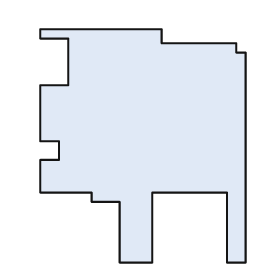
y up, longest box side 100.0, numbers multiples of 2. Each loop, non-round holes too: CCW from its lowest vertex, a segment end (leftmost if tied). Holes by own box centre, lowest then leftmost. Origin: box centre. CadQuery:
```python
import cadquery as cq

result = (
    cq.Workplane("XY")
    .moveTo(-10.0, -50.0)
    .lineTo(4.0, -50.0)
    .lineTo(4.0, -20.0)
    .lineTo(36.0, -20.0)
    .lineTo(36.0, -50.0)
    .lineTo(44.0, -50.0)
    .lineTo(44.0, 40.0)
    .lineTo(40.0, 40.0)
    .lineTo(40.0, 44.0)
    .lineTo(8.0, 44.0)
    .lineTo(8.0, 50.0)
    .lineTo(-44.0, 50.0)
    .lineTo(-44.0, 46.0)
    .lineTo(-32.0, 46.0)
    .lineTo(-32.0, 26.0)
    .lineTo(-44.0, 26.0)
    .lineTo(-44.0, 2.0)
    .lineTo(-36.0, 2.0)
    .lineTo(-36.0, -6.0)
    .lineTo(-44.0, -6.0)
    .lineTo(-44.0, -20.0)
    .lineTo(-22.0, -20.0)
    .lineTo(-22.0, -24.0)
    .lineTo(-10.0, -24.0)
    .close()
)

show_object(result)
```